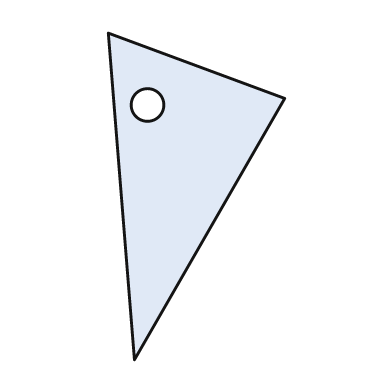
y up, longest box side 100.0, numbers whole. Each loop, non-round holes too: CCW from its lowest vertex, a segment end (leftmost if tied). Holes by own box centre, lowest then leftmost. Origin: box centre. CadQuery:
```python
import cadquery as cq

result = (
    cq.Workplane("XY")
    .moveTo(-19.0, -50.0)
    .lineTo(27.0, 30.0)
    .lineTo(-27.0, 50.0)
    .close()
    .moveTo(-15.0, 28.0)
    .circle(5.0)
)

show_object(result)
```